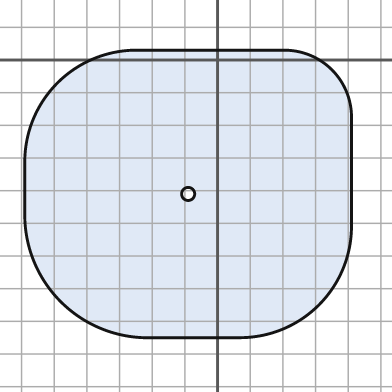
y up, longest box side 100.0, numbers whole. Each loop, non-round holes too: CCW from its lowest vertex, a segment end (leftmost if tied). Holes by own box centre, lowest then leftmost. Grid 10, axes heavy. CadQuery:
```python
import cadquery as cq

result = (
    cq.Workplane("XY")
    .moveTo(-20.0, -85.0)
    .lineTo(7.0, -85.0)
    .threePointArc((31.0, -75.0), (41.0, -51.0))
    .lineTo(41.0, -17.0)
    .threePointArc((35.0, -3.0), (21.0, 3.0))
    .lineTo(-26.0, 3.0)
    .threePointArc((-49.0, -7.0), (-59.0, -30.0))
    .lineTo(-59.0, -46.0)
    .threePointArc((-48.0, -74.0), (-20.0, -85.0))
    .close()
    .moveTo(-9.0, -41.0)
    .circle(2.0)
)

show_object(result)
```